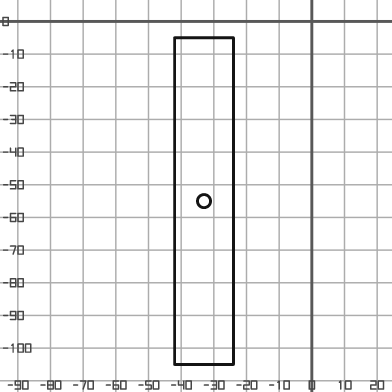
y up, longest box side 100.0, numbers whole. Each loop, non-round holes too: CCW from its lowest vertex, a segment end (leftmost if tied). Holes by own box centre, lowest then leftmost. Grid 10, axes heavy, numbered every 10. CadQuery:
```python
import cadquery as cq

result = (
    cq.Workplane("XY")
    .moveTo(-42.0, -105.0)
    .lineTo(-24.0, -105.0)
    .lineTo(-24.0, -5.0)
    .lineTo(-42.0, -5.0)
    .close()
    .moveTo(-33.0, -55.0)
    .circle(2.0)
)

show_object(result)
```